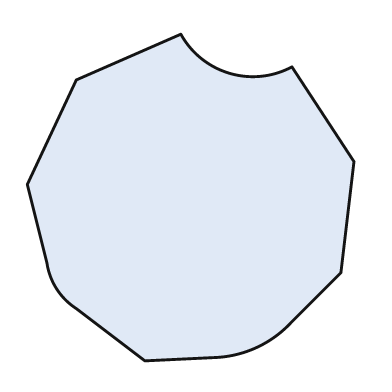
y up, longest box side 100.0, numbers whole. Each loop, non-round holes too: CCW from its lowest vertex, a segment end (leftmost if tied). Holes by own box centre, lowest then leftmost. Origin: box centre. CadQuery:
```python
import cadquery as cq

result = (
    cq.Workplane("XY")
    .moveTo(-14.0, -50.0)
    .lineTo(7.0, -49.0)
    .threePointArc((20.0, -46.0), (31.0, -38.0))
    .lineTo(46.0, -23.0)
    .lineTo(50.0, 11.0)
    .lineTo(31.0, 40.0)
    .threePointArc((12.0, 38.0), (-3.0, 50.0))
    .lineTo(-35.0, 36.0)
    .lineTo(-50.0, 4.0)
    .lineTo(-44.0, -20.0)
    .threePointArc((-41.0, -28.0), (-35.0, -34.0))
    .close()
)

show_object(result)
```